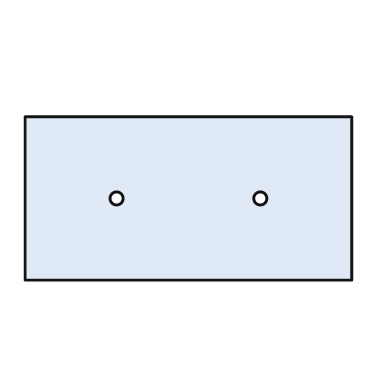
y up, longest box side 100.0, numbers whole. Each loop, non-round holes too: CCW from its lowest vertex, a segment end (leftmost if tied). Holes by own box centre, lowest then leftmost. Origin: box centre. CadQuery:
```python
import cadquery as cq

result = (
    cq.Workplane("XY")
    .moveTo(-50.0, -25.0)
    .lineTo(50.0, -25.0)
    .lineTo(50.0, 25.0)
    .lineTo(-50.0, 25.0)
    .close()
    .moveTo(-22.0, 0.0)
    .circle(2.0)
    .moveTo(22.0, 0.0)
    .circle(2.0)
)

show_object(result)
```